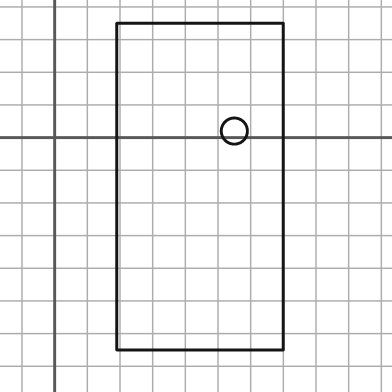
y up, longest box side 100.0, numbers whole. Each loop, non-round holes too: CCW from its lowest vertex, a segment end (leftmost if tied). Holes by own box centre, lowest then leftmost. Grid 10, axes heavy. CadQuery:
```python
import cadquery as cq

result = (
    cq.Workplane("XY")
    .moveTo(19.0, -65.0)
    .lineTo(70.0, -65.0)
    .lineTo(70.0, 35.0)
    .lineTo(19.0, 35.0)
    .close()
    .moveTo(55.0, 2.0)
    .circle(4.0)
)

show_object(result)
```